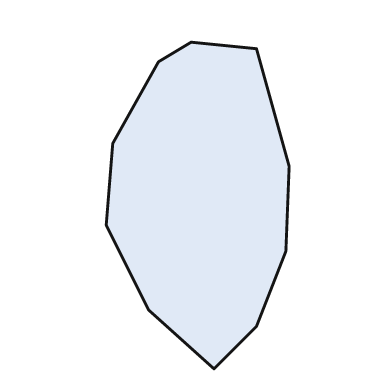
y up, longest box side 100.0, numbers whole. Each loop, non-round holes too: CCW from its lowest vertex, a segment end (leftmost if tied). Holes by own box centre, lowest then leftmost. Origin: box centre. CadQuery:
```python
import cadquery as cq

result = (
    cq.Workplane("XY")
    .moveTo(5.0, -50.0)
    .lineTo(18.0, -37.0)
    .lineTo(27.0, -14.0)
    .lineTo(28.0, 12.0)
    .lineTo(18.0, 48.0)
    .lineTo(-2.0, 50.0)
    .lineTo(-12.0, 44.0)
    .lineTo(-26.0, 19.0)
    .lineTo(-28.0, -6.0)
    .lineTo(-15.0, -32.0)
    .close()
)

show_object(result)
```